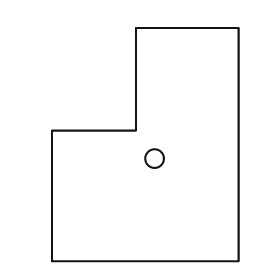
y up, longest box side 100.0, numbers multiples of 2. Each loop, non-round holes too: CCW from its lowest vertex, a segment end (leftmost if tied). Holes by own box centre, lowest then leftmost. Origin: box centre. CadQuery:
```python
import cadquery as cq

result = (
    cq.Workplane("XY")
    .moveTo(-40.0, -50.0)
    .lineTo(40.0, -50.0)
    .lineTo(40.0, 50.0)
    .lineTo(-4.0, 50.0)
    .lineTo(-4.0, 6.0)
    .lineTo(-40.0, 6.0)
    .close()
    .moveTo(4.0, -6.0)
    .circle(4.0)
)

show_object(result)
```